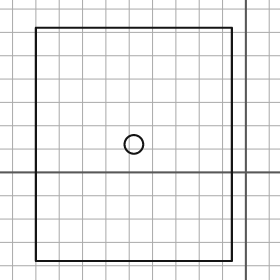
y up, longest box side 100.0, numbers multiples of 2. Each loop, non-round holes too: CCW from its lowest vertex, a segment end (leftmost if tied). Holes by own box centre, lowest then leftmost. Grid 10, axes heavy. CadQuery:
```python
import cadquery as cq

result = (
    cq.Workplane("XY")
    .moveTo(-90.0, -38.0)
    .lineTo(-6.0, -38.0)
    .lineTo(-6.0, 62.0)
    .lineTo(-90.0, 62.0)
    .close()
    .moveTo(-48.0, 12.0)
    .circle(4.0)
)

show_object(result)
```